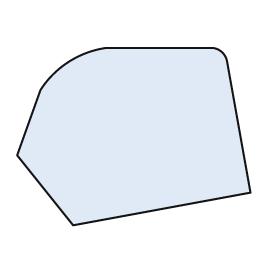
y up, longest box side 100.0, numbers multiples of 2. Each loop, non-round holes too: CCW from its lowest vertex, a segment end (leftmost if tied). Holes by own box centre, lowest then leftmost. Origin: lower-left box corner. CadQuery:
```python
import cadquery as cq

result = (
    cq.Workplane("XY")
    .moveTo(24.0, 0.0)
    .lineTo(100.0, 14.0)
    .lineTo(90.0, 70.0)
    .threePointArc((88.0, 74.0), (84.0, 76.0))
    .lineTo(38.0, 76.0)
    .threePointArc((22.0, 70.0), (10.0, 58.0))
    .lineTo(0.0, 30.0)
    .close()
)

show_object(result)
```